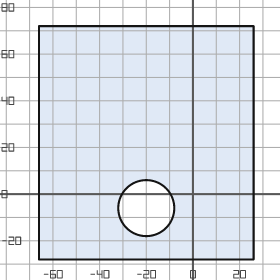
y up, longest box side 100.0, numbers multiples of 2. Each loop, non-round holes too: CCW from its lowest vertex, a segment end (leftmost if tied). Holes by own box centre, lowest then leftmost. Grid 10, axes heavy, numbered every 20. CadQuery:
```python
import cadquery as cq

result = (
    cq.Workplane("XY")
    .moveTo(-66.0, -28.0)
    .lineTo(26.0, -28.0)
    .lineTo(26.0, 72.0)
    .lineTo(-66.0, 72.0)
    .close()
    .moveTo(-20.0, -6.0)
    .circle(12.0)
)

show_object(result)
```